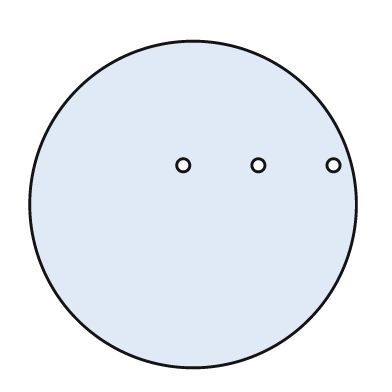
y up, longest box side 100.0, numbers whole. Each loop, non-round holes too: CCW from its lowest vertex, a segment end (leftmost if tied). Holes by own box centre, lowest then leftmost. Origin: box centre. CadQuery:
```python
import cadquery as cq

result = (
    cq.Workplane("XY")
    .moveTo(0.0, 0.0)
    .circle(50.0)
    .moveTo(-3.0, 12.0)
    .circle(2.0)
    .moveTo(20.0, 12.0)
    .circle(2.0)
    .moveTo(43.0, 12.0)
    .circle(2.0)
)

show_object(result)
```